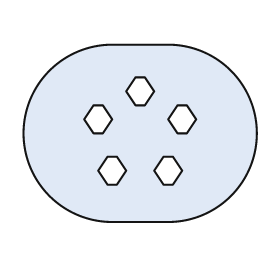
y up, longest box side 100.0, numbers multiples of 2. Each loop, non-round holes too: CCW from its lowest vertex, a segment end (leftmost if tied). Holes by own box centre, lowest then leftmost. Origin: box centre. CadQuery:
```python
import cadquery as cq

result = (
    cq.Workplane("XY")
    .moveTo(-12.0, -38.0)
    .lineTo(12.0, -38.0)
    .threePointArc((50.0, 0.0), (12.0, 38.0))
    .lineTo(-12.0, 38.0)
    .threePointArc((-50.0, 0.0), (-12.0, -38.0))
    .close()
    .moveTo(-14.0, -22.0)
    .lineTo(-10.0, -22.0)
    .lineTo(-6.0, -16.0)
    .lineTo(-10.0, -10.0)
    .lineTo(-14.0, -10.0)
    .lineTo(-18.0, -16.0)
    .close()
    .moveTo(10.0, -22.0)
    .lineTo(14.0, -22.0)
    .lineTo(18.0, -16.0)
    .lineTo(14.0, -10.0)
    .lineTo(10.0, -10.0)
    .lineTo(6.0, -16.0)
    .close()
    .moveTo(-20.0, 0.0)
    .lineTo(-16.0, 0.0)
    .lineTo(-12.0, 6.0)
    .lineTo(-16.0, 12.0)
    .lineTo(-20.0, 12.0)
    .lineTo(-24.0, 6.0)
    .close()
    .moveTo(16.0, 0.0)
    .lineTo(20.0, 0.0)
    .lineTo(24.0, 6.0)
    .lineTo(20.0, 12.0)
    .lineTo(16.0, 12.0)
    .lineTo(12.0, 6.0)
    .close()
    .moveTo(-2.0, 12.0)
    .lineTo(2.0, 12.0)
    .lineTo(6.0, 18.0)
    .lineTo(2.0, 24.0)
    .lineTo(-2.0, 24.0)
    .lineTo(-6.0, 18.0)
    .close()
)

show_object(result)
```